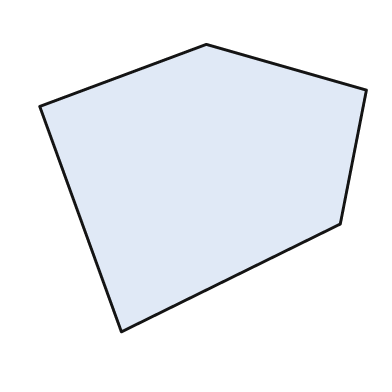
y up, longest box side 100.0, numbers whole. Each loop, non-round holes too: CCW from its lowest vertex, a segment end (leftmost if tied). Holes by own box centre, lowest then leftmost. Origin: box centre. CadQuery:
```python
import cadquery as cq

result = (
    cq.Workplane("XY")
    .moveTo(-25.0, -44.0)
    .lineTo(42.0, -11.0)
    .lineTo(50.0, 30.0)
    .lineTo(1.0, 44.0)
    .lineTo(-50.0, 25.0)
    .close()
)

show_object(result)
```